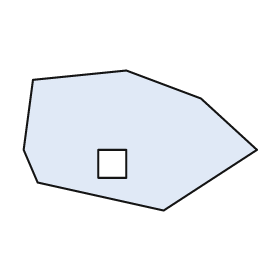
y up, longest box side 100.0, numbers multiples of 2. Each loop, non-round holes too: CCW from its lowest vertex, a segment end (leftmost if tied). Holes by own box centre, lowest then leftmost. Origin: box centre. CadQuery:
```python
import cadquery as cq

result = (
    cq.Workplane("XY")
    .moveTo(10.0, -30.0)
    .lineTo(50.0, -4.0)
    .lineTo(26.0, 18.0)
    .lineTo(-6.0, 30.0)
    .lineTo(-46.0, 26.0)
    .lineTo(-50.0, -4.0)
    .lineTo(-44.0, -18.0)
    .close()
    .moveTo(-18.0, -16.0)
    .lineTo(-6.0, -16.0)
    .lineTo(-6.0, -4.0)
    .lineTo(-18.0, -4.0)
    .close()
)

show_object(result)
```